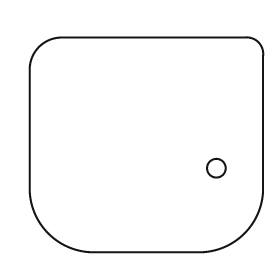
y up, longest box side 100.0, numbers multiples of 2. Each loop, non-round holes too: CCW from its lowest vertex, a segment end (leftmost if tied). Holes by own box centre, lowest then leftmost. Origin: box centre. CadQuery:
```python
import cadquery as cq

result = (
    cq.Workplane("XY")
    .moveTo(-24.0, -46.0)
    .lineTo(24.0, -46.0)
    .threePointArc((42.0, -38.0), (50.0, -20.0))
    .lineTo(50.0, 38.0)
    .threePointArc((48.0, 44.0), (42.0, 46.0))
    .lineTo(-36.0, 46.0)
    .threePointArc((-46.0, 42.0), (-50.0, 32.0))
    .lineTo(-50.0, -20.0)
    .threePointArc((-42.0, -38.0), (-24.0, -46.0))
    .close()
    .moveTo(30.0, -10.0)
    .circle(4.0)
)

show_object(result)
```